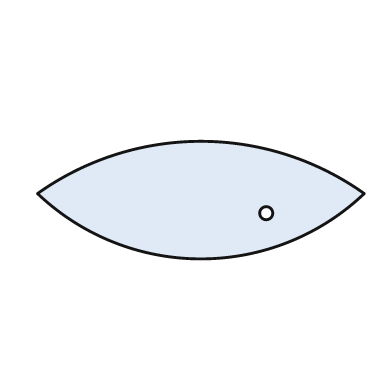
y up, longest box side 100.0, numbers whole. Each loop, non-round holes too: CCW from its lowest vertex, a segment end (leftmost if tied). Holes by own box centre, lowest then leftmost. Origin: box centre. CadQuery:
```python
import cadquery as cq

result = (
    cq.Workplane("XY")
    .moveTo(-50.0, 2.0)
    .threePointArc((0.0, -18.0), (50.0, 2.0))
    .threePointArc((0.0, 18.0), (-50.0, 2.0))
    .close()
    .moveTo(20.0, -4.0)
    .circle(2.0)
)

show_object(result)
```